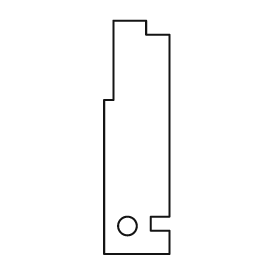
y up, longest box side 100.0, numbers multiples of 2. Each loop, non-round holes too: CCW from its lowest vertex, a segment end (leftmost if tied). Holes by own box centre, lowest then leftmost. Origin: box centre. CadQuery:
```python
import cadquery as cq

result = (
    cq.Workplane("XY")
    .moveTo(-14.0, -50.0)
    .lineTo(14.0, -50.0)
    .lineTo(14.0, -40.0)
    .lineTo(6.0, -40.0)
    .lineTo(6.0, -34.0)
    .lineTo(14.0, -34.0)
    .lineTo(14.0, 44.0)
    .lineTo(4.0, 44.0)
    .lineTo(4.0, 50.0)
    .lineTo(-10.0, 50.0)
    .lineTo(-10.0, 16.0)
    .lineTo(-14.0, 16.0)
    .close()
    .moveTo(-4.0, -38.0)
    .circle(4.0)
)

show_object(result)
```